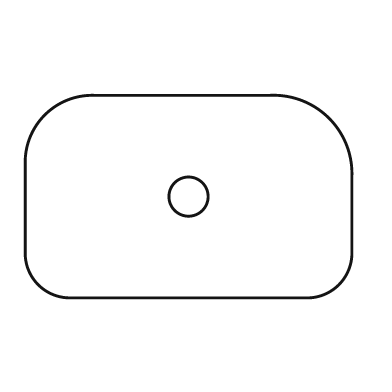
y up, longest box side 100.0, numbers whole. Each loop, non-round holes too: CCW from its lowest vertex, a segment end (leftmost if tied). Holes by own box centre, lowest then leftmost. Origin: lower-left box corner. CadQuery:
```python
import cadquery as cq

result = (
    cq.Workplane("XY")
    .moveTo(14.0, 0.0)
    .lineTo(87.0, 0.0)
    .threePointArc((96.0, 4.0), (100.0, 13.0))
    .lineTo(100.0, 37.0)
    .threePointArc((93.0, 55.0), (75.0, 62.0))
    .lineTo(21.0, 62.0)
    .threePointArc((6.0, 56.0), (0.0, 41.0))
    .lineTo(0.0, 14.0)
    .threePointArc((4.0, 4.0), (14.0, 0.0))
    .close()
    .moveTo(50.0, 31.0)
    .circle(6.0)
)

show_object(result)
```